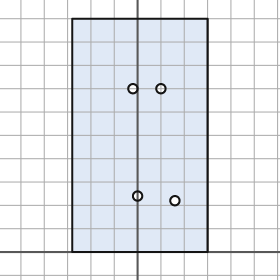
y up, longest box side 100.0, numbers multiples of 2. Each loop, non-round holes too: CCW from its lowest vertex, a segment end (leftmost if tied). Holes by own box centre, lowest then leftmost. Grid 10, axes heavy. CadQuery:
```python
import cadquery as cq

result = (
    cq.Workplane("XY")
    .moveTo(-28.0, 0.0)
    .lineTo(30.0, 0.0)
    .lineTo(30.0, 100.0)
    .lineTo(-28.0, 100.0)
    .close()
    .moveTo(16.0, 22.0)
    .circle(2.0)
    .moveTo(0.0, 24.0)
    .circle(2.0)
    .moveTo(-2.0, 70.0)
    .circle(2.0)
    .moveTo(10.0, 70.0)
    .circle(2.0)
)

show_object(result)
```